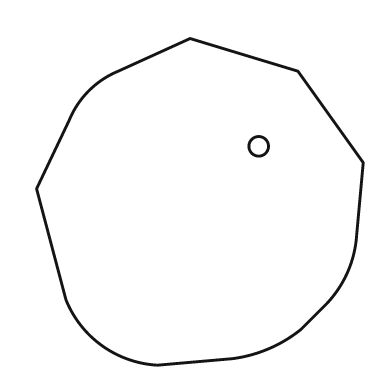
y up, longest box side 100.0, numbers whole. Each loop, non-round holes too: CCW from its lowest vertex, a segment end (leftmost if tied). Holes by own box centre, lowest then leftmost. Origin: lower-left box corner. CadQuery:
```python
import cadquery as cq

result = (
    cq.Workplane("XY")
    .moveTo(37.0, 0.0)
    .lineTo(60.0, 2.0)
    .threePointArc((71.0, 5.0), (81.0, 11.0))
    .lineTo(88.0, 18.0)
    .threePointArc((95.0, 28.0), (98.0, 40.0))
    .lineTo(100.0, 62.0)
    .lineTo(80.0, 90.0)
    .lineTo(47.0, 100.0)
    .lineTo(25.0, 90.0)
    .threePointArc((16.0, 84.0), (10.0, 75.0))
    .lineTo(0.0, 54.0)
    .lineTo(9.0, 20.0)
    .threePointArc((20.0, 6.0), (37.0, 0.0))
    .close()
    .moveTo(68.0, 67.0)
    .circle(3.0)
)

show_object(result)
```